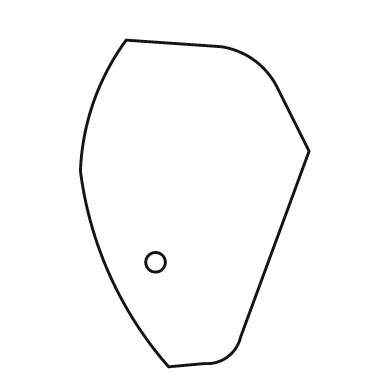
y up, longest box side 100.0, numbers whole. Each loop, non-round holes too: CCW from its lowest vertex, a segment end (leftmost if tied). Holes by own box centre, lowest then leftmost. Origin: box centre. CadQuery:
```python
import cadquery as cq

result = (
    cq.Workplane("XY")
    .moveTo(-8.0, -50.0)
    .lineTo(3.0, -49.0)
    .threePointArc((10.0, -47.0), (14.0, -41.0))
    .lineTo(35.0, 16.0)
    .lineTo(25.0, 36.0)
    .threePointArc((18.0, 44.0), (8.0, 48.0))
    .lineTo(-21.0, 50.0)
    .threePointArc((-31.0, 31.0), (-35.0, 10.0))
    .threePointArc((-26.0, -22.0), (-8.0, -50.0))
    .close()
    .moveTo(-12.0, -18.0)
    .circle(3.0)
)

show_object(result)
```